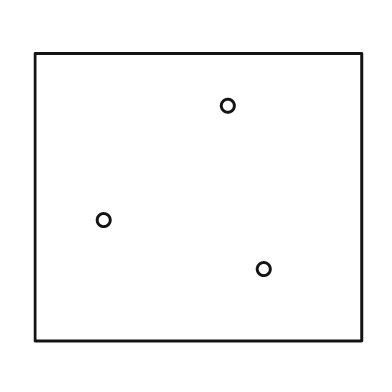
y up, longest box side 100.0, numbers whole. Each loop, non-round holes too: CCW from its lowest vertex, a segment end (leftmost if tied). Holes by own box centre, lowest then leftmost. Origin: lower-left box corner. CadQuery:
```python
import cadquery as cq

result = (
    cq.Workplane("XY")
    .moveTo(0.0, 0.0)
    .lineTo(100.0, 0.0)
    .lineTo(100.0, 88.0)
    .lineTo(0.0, 88.0)
    .close()
    .moveTo(70.0, 22.0)
    .circle(2.0)
    .moveTo(21.0, 37.0)
    .circle(2.0)
    .moveTo(59.0, 72.0)
    .circle(2.0)
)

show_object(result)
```